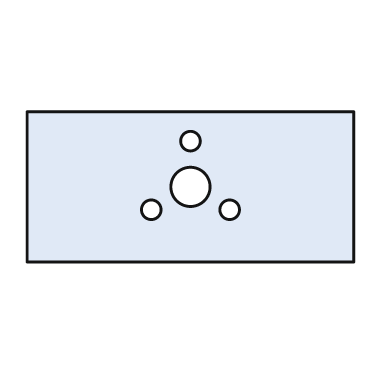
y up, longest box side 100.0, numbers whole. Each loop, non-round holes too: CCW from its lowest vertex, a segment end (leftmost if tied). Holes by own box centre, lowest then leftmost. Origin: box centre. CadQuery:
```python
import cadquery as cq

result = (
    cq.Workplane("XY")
    .moveTo(-50.0, -23.0)
    .lineTo(50.0, -23.0)
    .lineTo(50.0, 23.0)
    .lineTo(-50.0, 23.0)
    .close()
    .moveTo(-12.0, -7.0)
    .circle(3.0)
    .moveTo(12.0, -7.0)
    .circle(3.0)
    .moveTo(0.0, 0.0)
    .circle(6.0)
    .moveTo(0.0, 14.0)
    .circle(3.0)
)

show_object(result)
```